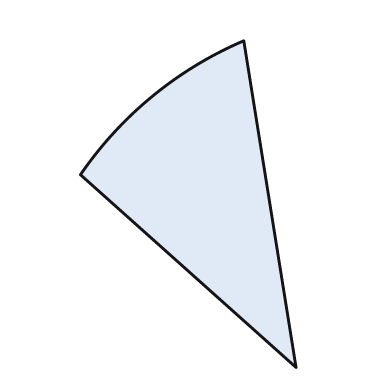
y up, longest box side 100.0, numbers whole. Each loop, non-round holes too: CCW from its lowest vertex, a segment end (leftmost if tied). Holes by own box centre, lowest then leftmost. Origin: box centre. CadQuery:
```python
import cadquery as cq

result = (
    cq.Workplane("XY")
    .moveTo(33.0, -50.0)
    .lineTo(17.0, 50.0)
    .threePointArc((-11.0, 33.0), (-33.0, 9.0))
    .close()
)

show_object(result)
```